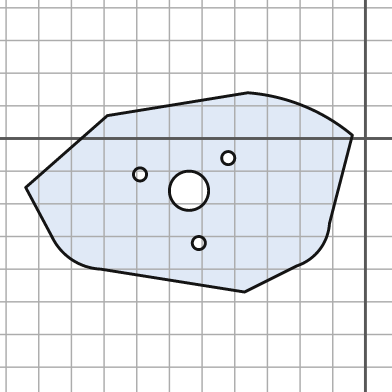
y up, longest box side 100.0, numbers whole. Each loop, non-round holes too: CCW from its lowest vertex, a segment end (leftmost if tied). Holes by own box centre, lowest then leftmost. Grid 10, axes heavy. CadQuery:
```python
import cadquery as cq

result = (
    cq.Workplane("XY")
    .moveTo(-37.0, -47.0)
    .lineTo(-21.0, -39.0)
    .threePointArc((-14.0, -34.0), (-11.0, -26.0))
    .lineTo(-4.0, 1.0)
    .threePointArc((-19.0, 10.0), (-36.0, 14.0))
    .lineTo(-79.0, 7.0)
    .lineTo(-104.0, -15.0)
    .lineTo(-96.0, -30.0)
    .threePointArc((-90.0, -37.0), (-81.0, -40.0))
    .close()
    .moveTo(-51.0, -32.0)
    .circle(2.0)
    .moveTo(-54.0, -16.0)
    .circle(6.0)
    .moveTo(-69.0, -11.0)
    .circle(2.0)
    .moveTo(-42.0, -6.0)
    .circle(2.0)
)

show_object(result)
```